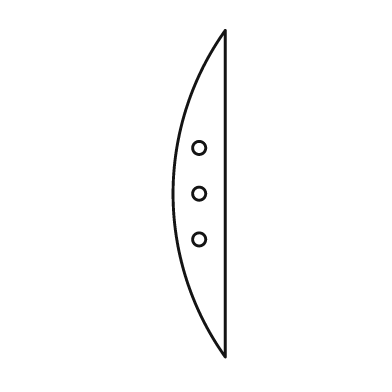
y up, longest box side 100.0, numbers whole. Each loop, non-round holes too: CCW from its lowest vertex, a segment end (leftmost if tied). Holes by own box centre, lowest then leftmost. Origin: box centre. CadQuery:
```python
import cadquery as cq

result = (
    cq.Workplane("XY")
    .moveTo(8.0, -50.0)
    .lineTo(8.0, 50.0)
    .threePointArc((-8.0, 0.0), (8.0, -50.0))
    .close()
    .moveTo(0.0, -14.0)
    .circle(2.0)
    .moveTo(0.0, 0.0)
    .circle(2.0)
    .moveTo(0.0, 14.0)
    .circle(2.0)
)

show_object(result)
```